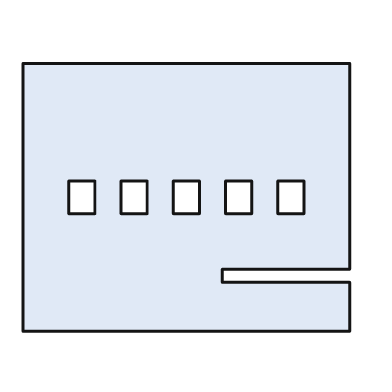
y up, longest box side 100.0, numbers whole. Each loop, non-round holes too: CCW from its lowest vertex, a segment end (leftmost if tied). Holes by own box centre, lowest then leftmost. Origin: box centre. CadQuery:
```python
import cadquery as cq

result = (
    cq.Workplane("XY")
    .moveTo(-50.0, -41.0)
    .lineTo(50.0, -41.0)
    .lineTo(50.0, -26.0)
    .lineTo(11.0, -26.0)
    .lineTo(11.0, -22.0)
    .lineTo(50.0, -22.0)
    .lineTo(50.0, 41.0)
    .lineTo(-50.0, 41.0)
    .close()
    .moveTo(-36.0, -5.0)
    .lineTo(-28.0, -5.0)
    .lineTo(-28.0, 5.0)
    .lineTo(-36.0, 5.0)
    .close()
    .moveTo(-20.0, -5.0)
    .lineTo(-12.0, -5.0)
    .lineTo(-12.0, 5.0)
    .lineTo(-20.0, 5.0)
    .close()
    .moveTo(-4.0, -5.0)
    .lineTo(4.0, -5.0)
    .lineTo(4.0, 5.0)
    .lineTo(-4.0, 5.0)
    .close()
    .moveTo(12.0, -5.0)
    .lineTo(20.0, -5.0)
    .lineTo(20.0, 5.0)
    .lineTo(12.0, 5.0)
    .close()
    .moveTo(28.0, -5.0)
    .lineTo(36.0, -5.0)
    .lineTo(36.0, 5.0)
    .lineTo(28.0, 5.0)
    .close()
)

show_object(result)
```